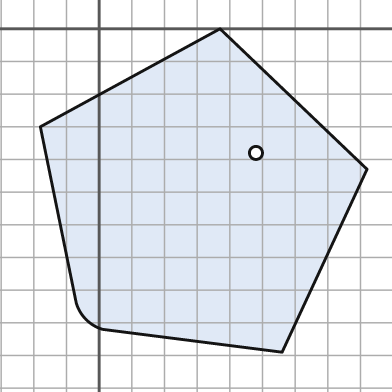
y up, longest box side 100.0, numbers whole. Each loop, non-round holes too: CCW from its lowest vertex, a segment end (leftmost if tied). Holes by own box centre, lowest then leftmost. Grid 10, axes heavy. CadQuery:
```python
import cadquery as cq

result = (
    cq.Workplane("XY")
    .moveTo(56.0, -99.0)
    .lineTo(82.0, -43.0)
    .lineTo(37.0, 0.0)
    .lineTo(-18.0, -30.0)
    .lineTo(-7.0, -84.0)
    .threePointArc((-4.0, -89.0), (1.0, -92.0))
    .close()
    .moveTo(48.0, -38.0)
    .circle(2.0)
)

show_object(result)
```